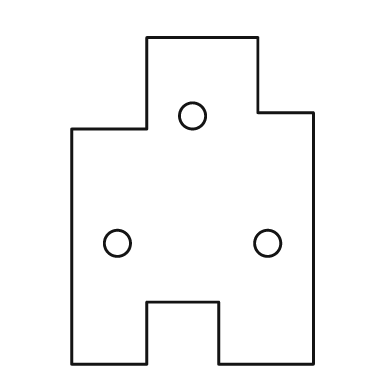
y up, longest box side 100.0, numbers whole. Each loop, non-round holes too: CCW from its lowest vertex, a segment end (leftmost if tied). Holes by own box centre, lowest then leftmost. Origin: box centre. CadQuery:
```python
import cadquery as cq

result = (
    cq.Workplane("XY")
    .moveTo(-37.0, -50.0)
    .lineTo(-14.0, -50.0)
    .lineTo(-14.0, -31.0)
    .lineTo(8.0, -31.0)
    .lineTo(8.0, -50.0)
    .lineTo(37.0, -50.0)
    .lineTo(37.0, 27.0)
    .lineTo(20.0, 27.0)
    .lineTo(20.0, 50.0)
    .lineTo(-14.0, 50.0)
    .lineTo(-14.0, 22.0)
    .lineTo(-37.0, 22.0)
    .close()
    .moveTo(-23.0, -13.0)
    .circle(4.0)
    .moveTo(23.0, -13.0)
    .circle(4.0)
    .moveTo(0.0, 26.0)
    .circle(4.0)
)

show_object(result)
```